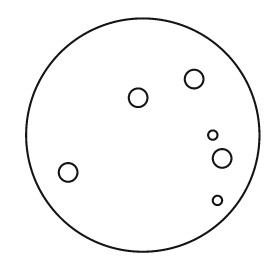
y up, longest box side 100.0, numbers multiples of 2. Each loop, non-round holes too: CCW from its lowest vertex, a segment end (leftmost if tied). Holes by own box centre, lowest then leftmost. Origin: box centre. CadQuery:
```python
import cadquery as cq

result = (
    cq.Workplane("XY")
    .moveTo(0.0, 0.0)
    .circle(50.0)
    .moveTo(32.0, -28.0)
    .circle(2.0)
    .moveTo(-32.0, -16.0)
    .circle(4.0)
    .moveTo(34.0, -10.0)
    .circle(4.0)
    .moveTo(30.0, 0.0)
    .circle(2.0)
    .moveTo(-2.0, 16.0)
    .circle(4.0)
    .moveTo(22.0, 24.0)
    .circle(4.0)
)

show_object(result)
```